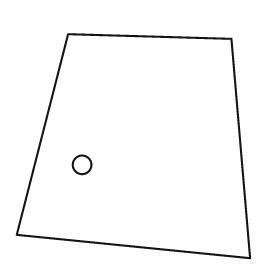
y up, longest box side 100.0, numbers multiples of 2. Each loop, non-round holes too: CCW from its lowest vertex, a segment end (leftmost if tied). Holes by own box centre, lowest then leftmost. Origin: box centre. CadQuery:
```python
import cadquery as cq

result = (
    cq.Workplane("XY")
    .moveTo(50.0, -48.0)
    .lineTo(42.0, 46.0)
    .lineTo(-28.0, 48.0)
    .lineTo(-50.0, -38.0)
    .close()
    .moveTo(-22.0, -8.0)
    .circle(4.0)
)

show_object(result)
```